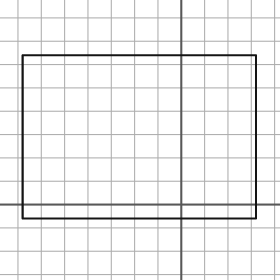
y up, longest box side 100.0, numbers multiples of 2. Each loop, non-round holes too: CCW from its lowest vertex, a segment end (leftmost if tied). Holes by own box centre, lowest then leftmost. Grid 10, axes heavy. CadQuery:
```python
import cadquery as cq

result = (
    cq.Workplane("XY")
    .moveTo(-68.0, -6.0)
    .lineTo(32.0, -6.0)
    .lineTo(32.0, 64.0)
    .lineTo(-68.0, 64.0)
    .close()
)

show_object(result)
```